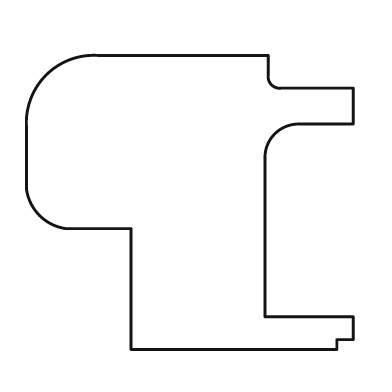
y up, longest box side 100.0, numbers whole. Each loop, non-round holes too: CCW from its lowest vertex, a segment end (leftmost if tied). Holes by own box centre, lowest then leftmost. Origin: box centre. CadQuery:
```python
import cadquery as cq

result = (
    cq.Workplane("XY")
    .moveTo(-18.0, -45.0)
    .lineTo(45.0, -45.0)
    .lineTo(45.0, -42.0)
    .lineTo(50.0, -42.0)
    .lineTo(50.0, -35.0)
    .lineTo(23.0, -35.0)
    .lineTo(23.0, 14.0)
    .threePointArc((26.0, 21.0), (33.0, 24.0))
    .lineTo(50.0, 24.0)
    .lineTo(50.0, 35.0)
    .lineTo(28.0, 35.0)
    .threePointArc((25.0, 36.0), (24.0, 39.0))
    .lineTo(24.0, 45.0)
    .lineTo(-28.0, 45.0)
    .threePointArc((-44.0, 39.0), (-50.0, 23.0))
    .lineTo(-50.0, 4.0)
    .threePointArc((-46.0, -4.0), (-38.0, -8.0))
    .lineTo(-18.0, -8.0)
    .close()
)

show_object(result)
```